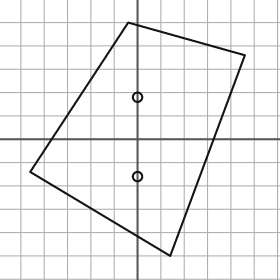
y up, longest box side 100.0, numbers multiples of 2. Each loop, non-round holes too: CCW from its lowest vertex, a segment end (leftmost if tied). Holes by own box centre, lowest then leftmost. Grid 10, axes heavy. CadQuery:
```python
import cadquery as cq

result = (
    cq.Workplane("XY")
    .moveTo(14.0, -50.0)
    .lineTo(46.0, 36.0)
    .lineTo(-4.0, 50.0)
    .lineTo(-46.0, -14.0)
    .close()
    .moveTo(0.0, -16.0)
    .circle(2.0)
    .moveTo(0.0, 18.0)
    .circle(2.0)
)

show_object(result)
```